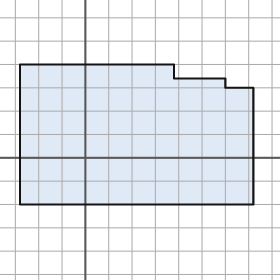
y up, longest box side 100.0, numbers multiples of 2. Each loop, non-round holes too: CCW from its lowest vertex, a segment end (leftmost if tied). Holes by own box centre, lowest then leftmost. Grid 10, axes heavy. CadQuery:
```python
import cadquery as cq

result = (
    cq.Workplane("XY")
    .moveTo(-28.0, -20.0)
    .lineTo(72.0, -20.0)
    .lineTo(72.0, 30.0)
    .lineTo(60.0, 30.0)
    .lineTo(60.0, 34.0)
    .lineTo(38.0, 34.0)
    .lineTo(38.0, 40.0)
    .lineTo(-28.0, 40.0)
    .close()
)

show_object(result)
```